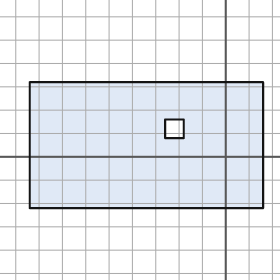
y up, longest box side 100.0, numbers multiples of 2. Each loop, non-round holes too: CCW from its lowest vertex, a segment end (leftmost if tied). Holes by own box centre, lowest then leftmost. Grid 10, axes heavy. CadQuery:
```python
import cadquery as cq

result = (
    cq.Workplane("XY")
    .moveTo(-84.0, -22.0)
    .lineTo(16.0, -22.0)
    .lineTo(16.0, 32.0)
    .lineTo(-84.0, 32.0)
    .close()
    .moveTo(-26.0, 8.0)
    .lineTo(-18.0, 8.0)
    .lineTo(-18.0, 16.0)
    .lineTo(-26.0, 16.0)
    .close()
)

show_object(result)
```